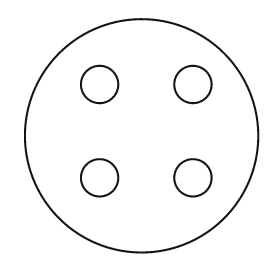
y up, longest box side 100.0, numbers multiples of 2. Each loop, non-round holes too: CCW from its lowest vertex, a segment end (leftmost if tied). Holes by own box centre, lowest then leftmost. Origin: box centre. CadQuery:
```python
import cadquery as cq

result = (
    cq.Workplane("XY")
    .moveTo(0.0, 0.0)
    .circle(50.0)
    .moveTo(-18.0, -18.0)
    .circle(8.0)
    .moveTo(22.0, -18.0)
    .circle(8.0)
    .moveTo(-18.0, 22.0)
    .circle(8.0)
    .moveTo(22.0, 22.0)
    .circle(8.0)
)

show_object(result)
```